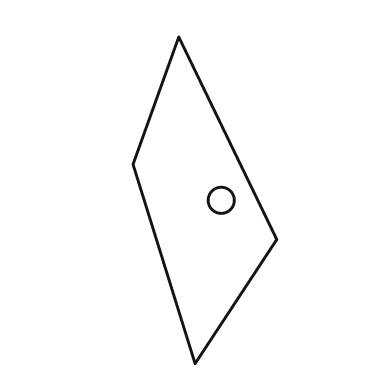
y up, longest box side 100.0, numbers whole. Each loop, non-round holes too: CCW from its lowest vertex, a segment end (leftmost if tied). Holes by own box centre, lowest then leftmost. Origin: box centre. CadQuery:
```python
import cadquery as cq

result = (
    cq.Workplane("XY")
    .moveTo(-3.0, -50.0)
    .lineTo(22.0, -12.0)
    .lineTo(-8.0, 50.0)
    .lineTo(-22.0, 11.0)
    .close()
    .moveTo(5.0, 0.0)
    .circle(4.0)
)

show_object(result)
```